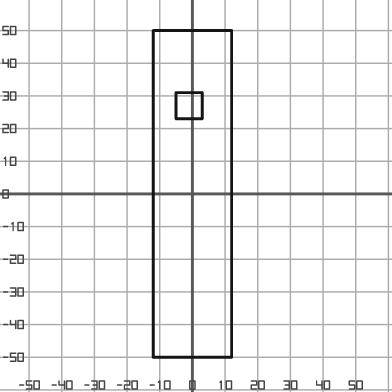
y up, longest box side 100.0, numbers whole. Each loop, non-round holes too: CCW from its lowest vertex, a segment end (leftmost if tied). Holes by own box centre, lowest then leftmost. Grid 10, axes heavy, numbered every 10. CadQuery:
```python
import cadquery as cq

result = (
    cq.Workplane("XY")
    .moveTo(-12.0, -50.0)
    .lineTo(12.0, -50.0)
    .lineTo(12.0, 50.0)
    .lineTo(-12.0, 50.0)
    .close()
    .moveTo(-5.0, 23.0)
    .lineTo(3.0, 23.0)
    .lineTo(3.0, 31.0)
    .lineTo(-5.0, 31.0)
    .close()
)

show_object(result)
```